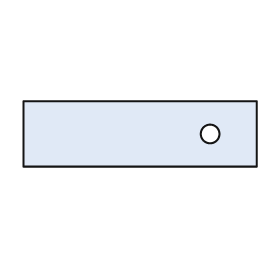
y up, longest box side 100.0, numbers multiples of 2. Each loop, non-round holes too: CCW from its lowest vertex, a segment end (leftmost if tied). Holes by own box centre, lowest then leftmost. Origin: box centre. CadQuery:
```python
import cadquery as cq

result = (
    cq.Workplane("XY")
    .moveTo(-50.0, -14.0)
    .lineTo(50.0, -14.0)
    .lineTo(50.0, 14.0)
    .lineTo(-50.0, 14.0)
    .close()
    .moveTo(30.0, 0.0)
    .circle(4.0)
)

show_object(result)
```